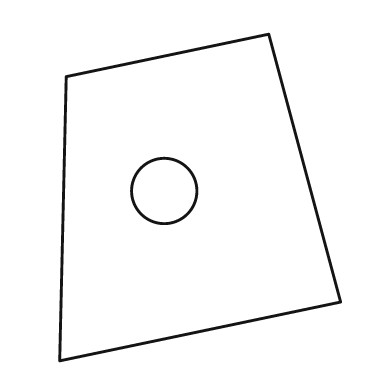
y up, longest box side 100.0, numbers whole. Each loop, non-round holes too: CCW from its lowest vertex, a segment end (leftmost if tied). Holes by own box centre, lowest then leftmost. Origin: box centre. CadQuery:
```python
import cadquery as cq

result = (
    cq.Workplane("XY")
    .moveTo(-43.0, -50.0)
    .lineTo(43.0, -32.0)
    .lineTo(21.0, 50.0)
    .lineTo(-41.0, 37.0)
    .close()
    .moveTo(-11.0, 2.0)
    .circle(10.0)
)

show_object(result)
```